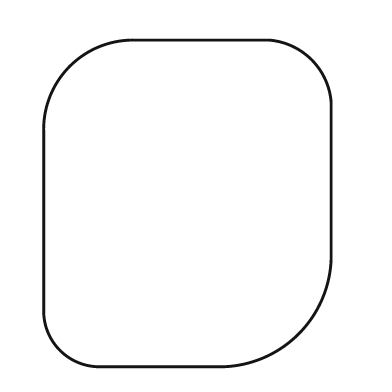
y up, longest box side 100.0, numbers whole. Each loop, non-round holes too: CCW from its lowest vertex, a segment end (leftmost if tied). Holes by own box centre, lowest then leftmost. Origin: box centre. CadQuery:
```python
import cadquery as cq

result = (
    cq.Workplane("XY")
    .moveTo(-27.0, -50.0)
    .lineTo(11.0, -50.0)
    .threePointArc((34.0, -40.0), (44.0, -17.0))
    .lineTo(44.0, 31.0)
    .threePointArc((38.0, 44.0), (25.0, 50.0))
    .lineTo(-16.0, 50.0)
    .threePointArc((-36.0, 42.0), (-44.0, 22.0))
    .lineTo(-44.0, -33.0)
    .threePointArc((-39.0, -45.0), (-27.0, -50.0))
    .close()
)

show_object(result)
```